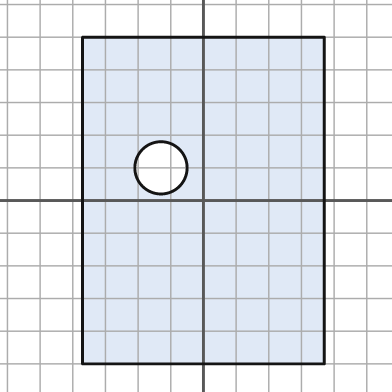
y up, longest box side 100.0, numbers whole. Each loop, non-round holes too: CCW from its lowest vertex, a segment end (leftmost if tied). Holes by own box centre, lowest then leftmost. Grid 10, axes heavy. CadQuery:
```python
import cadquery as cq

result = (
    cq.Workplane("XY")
    .moveTo(-37.0, -50.0)
    .lineTo(37.0, -50.0)
    .lineTo(37.0, 50.0)
    .lineTo(-37.0, 50.0)
    .close()
    .moveTo(-13.0, 10.0)
    .circle(8.0)
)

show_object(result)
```